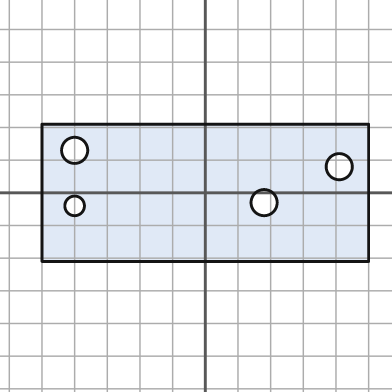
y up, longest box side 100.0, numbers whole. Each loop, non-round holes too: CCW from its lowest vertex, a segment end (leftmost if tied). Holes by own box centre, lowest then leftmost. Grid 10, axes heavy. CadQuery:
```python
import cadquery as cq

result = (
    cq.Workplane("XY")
    .moveTo(-50.0, -21.0)
    .lineTo(50.0, -21.0)
    .lineTo(50.0, 21.0)
    .lineTo(-50.0, 21.0)
    .close()
    .moveTo(-40.0, -4.0)
    .circle(3.0)
    .moveTo(18.0, -3.0)
    .circle(4.0)
    .moveTo(41.0, 8.0)
    .circle(4.0)
    .moveTo(-40.0, 13.0)
    .circle(4.0)
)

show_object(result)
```